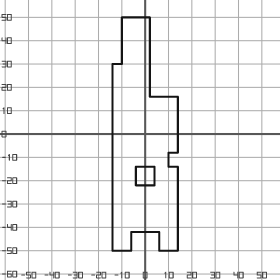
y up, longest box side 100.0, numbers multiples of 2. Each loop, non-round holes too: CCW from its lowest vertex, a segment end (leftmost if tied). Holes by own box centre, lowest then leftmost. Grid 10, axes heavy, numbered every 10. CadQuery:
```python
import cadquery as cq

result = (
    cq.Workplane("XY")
    .moveTo(-14.0, -50.0)
    .lineTo(-6.0, -50.0)
    .lineTo(-6.0, -42.0)
    .lineTo(6.0, -42.0)
    .lineTo(6.0, -50.0)
    .lineTo(14.0, -50.0)
    .lineTo(14.0, -14.0)
    .lineTo(10.0, -14.0)
    .lineTo(10.0, -8.0)
    .lineTo(14.0, -8.0)
    .lineTo(14.0, 16.0)
    .lineTo(2.0, 16.0)
    .lineTo(2.0, 50.0)
    .lineTo(-10.0, 50.0)
    .lineTo(-10.0, 30.0)
    .lineTo(-14.0, 30.0)
    .close()
    .moveTo(-4.0, -22.0)
    .lineTo(4.0, -22.0)
    .lineTo(4.0, -14.0)
    .lineTo(-4.0, -14.0)
    .close()
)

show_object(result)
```